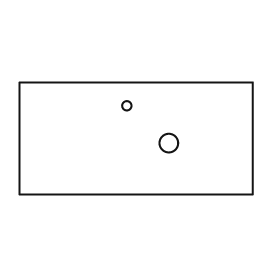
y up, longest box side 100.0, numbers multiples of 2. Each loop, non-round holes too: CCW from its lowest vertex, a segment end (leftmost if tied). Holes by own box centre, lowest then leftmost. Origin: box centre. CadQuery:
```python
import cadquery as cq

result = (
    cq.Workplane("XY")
    .moveTo(-50.0, -24.0)
    .lineTo(50.0, -24.0)
    .lineTo(50.0, 24.0)
    .lineTo(-50.0, 24.0)
    .close()
    .moveTo(14.0, -2.0)
    .circle(4.0)
    .moveTo(-4.0, 14.0)
    .circle(2.0)
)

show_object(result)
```